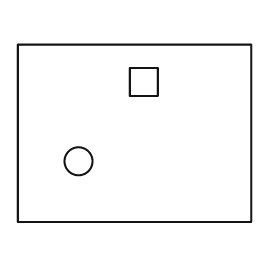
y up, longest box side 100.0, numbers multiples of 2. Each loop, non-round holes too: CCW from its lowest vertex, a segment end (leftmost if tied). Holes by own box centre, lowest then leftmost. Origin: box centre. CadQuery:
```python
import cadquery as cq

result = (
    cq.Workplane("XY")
    .moveTo(-50.0, -38.0)
    .lineTo(50.0, -38.0)
    .lineTo(50.0, 38.0)
    .lineTo(-50.0, 38.0)
    .close()
    .moveTo(-24.0, -12.0)
    .circle(6.0)
    .moveTo(-2.0, 16.0)
    .lineTo(10.0, 16.0)
    .lineTo(10.0, 28.0)
    .lineTo(-2.0, 28.0)
    .close()
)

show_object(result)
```